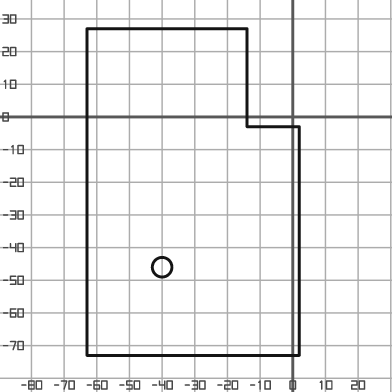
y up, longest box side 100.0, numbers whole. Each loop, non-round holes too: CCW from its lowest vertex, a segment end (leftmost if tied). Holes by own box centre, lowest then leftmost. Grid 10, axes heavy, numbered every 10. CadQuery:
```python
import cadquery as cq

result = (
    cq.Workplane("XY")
    .moveTo(-63.0, -73.0)
    .lineTo(2.0, -73.0)
    .lineTo(2.0, -3.0)
    .lineTo(-14.0, -3.0)
    .lineTo(-14.0, 27.0)
    .lineTo(-63.0, 27.0)
    .close()
    .moveTo(-40.0, -46.0)
    .circle(3.0)
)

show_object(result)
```